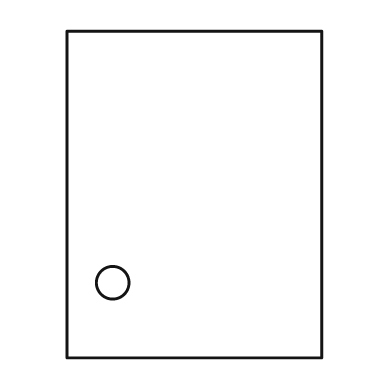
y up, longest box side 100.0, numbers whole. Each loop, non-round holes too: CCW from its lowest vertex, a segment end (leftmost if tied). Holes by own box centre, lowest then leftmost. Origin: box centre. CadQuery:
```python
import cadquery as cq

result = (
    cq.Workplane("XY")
    .moveTo(-39.0, -50.0)
    .lineTo(39.0, -50.0)
    .lineTo(39.0, 50.0)
    .lineTo(-39.0, 50.0)
    .close()
    .moveTo(-25.0, -27.0)
    .circle(5.0)
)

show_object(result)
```